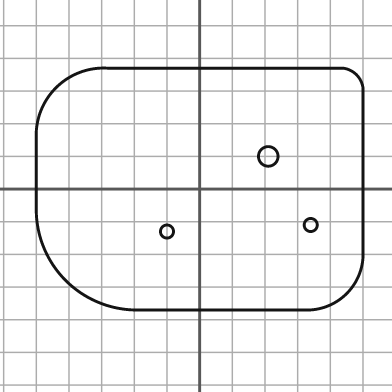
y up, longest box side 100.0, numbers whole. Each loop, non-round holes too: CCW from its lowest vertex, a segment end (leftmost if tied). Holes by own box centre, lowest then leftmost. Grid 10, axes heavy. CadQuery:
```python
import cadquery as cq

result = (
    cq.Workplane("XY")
    .moveTo(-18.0, -37.0)
    .lineTo(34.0, -37.0)
    .threePointArc((45.0, -32.0), (50.0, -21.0))
    .lineTo(50.0, 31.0)
    .threePointArc((48.0, 35.0), (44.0, 37.0))
    .lineTo(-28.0, 37.0)
    .threePointArc((-44.0, 31.0), (-50.0, 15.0))
    .lineTo(-50.0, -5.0)
    .threePointArc((-41.0, -28.0), (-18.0, -37.0))
    .close()
    .moveTo(-10.0, -13.0)
    .circle(2.0)
    .moveTo(34.0, -11.0)
    .circle(2.0)
    .moveTo(21.0, 10.0)
    .circle(3.0)
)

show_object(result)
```